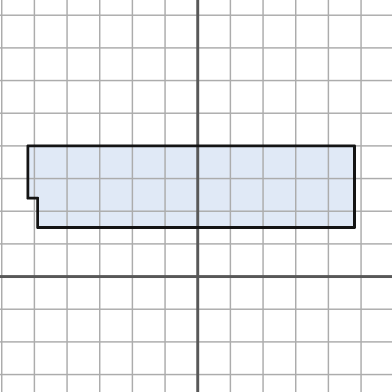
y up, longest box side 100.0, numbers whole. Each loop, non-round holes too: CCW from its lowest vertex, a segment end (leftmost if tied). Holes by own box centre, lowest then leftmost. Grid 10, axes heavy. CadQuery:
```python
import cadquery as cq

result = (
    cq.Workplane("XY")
    .moveTo(-49.0, 15.0)
    .lineTo(48.0, 15.0)
    .lineTo(48.0, 40.0)
    .lineTo(-52.0, 40.0)
    .lineTo(-52.0, 24.0)
    .lineTo(-49.0, 24.0)
    .close()
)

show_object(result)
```